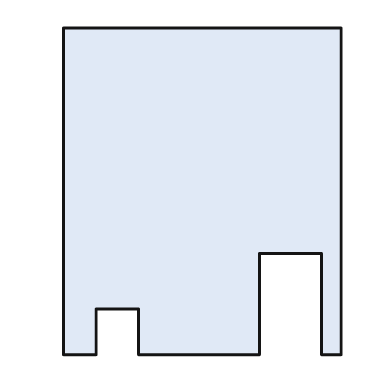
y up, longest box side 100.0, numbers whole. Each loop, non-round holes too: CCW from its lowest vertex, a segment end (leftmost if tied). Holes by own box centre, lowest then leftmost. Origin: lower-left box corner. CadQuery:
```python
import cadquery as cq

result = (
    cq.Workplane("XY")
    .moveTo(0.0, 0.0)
    .lineTo(10.0, 0.0)
    .lineTo(10.0, 14.0)
    .lineTo(23.0, 14.0)
    .lineTo(23.0, 0.0)
    .lineTo(60.0, 0.0)
    .lineTo(60.0, 31.0)
    .lineTo(79.0, 31.0)
    .lineTo(79.0, 0.0)
    .lineTo(85.0, 0.0)
    .lineTo(85.0, 100.0)
    .lineTo(0.0, 100.0)
    .close()
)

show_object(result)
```